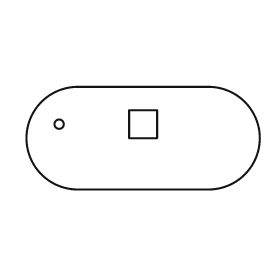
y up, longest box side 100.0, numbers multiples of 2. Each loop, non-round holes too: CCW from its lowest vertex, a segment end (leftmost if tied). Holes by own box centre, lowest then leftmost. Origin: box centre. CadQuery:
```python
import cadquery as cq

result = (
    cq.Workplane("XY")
    .moveTo(-28.0, -22.0)
    .lineTo(28.0, -22.0)
    .threePointArc((50.0, 0.0), (28.0, 22.0))
    .lineTo(-28.0, 22.0)
    .threePointArc((-50.0, 0.0), (-28.0, -22.0))
    .close()
    .moveTo(-36.0, 6.0)
    .circle(2.0)
    .moveTo(-6.0, 0.0)
    .lineTo(6.0, 0.0)
    .lineTo(6.0, 12.0)
    .lineTo(-6.0, 12.0)
    .close()
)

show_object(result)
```